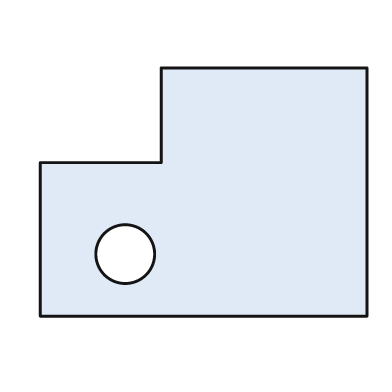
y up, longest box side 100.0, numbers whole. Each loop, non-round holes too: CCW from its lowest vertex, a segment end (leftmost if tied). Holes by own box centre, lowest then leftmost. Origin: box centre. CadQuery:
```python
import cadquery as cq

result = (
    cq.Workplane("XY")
    .moveTo(-50.0, -38.0)
    .lineTo(50.0, -38.0)
    .lineTo(50.0, 38.0)
    .lineTo(-13.0, 38.0)
    .lineTo(-13.0, 9.0)
    .lineTo(-50.0, 9.0)
    .close()
    .moveTo(-24.0, -19.0)
    .circle(9.0)
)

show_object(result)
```